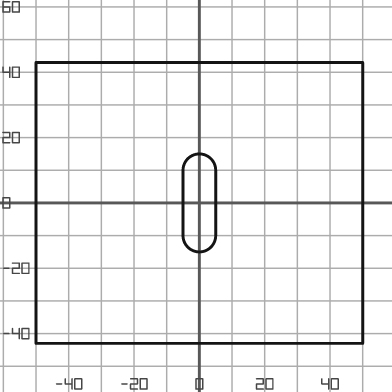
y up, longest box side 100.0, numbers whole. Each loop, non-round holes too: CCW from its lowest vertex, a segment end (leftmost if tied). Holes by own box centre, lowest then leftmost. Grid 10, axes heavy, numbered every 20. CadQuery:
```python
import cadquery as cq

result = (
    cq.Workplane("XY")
    .moveTo(-50.0, -43.0)
    .lineTo(50.0, -43.0)
    .lineTo(50.0, 43.0)
    .lineTo(-50.0, 43.0)
    .close()
    .moveTo(-5.0, -10.0)
    .threePointArc((0.0, -15.0), (5.0, -10.0))
    .lineTo(5.0, 10.0)
    .threePointArc((0.0, 15.0), (-5.0, 10.0))
    .close()
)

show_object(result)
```